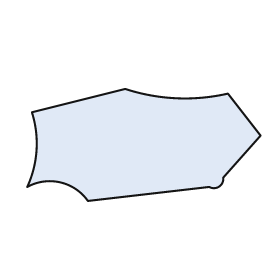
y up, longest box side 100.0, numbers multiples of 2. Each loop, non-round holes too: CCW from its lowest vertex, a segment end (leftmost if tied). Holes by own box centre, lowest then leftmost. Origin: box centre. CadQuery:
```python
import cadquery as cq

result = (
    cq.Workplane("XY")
    .moveTo(-24.0, -24.0)
    .lineTo(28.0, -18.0)
    .threePointArc((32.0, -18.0), (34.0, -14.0))
    .lineTo(50.0, 4.0)
    .lineTo(36.0, 22.0)
    .threePointArc((14.0, 20.0), (-8.0, 24.0))
    .lineTo(-48.0, 14.0)
    .threePointArc((-46.0, -2.0), (-50.0, -18.0))
    .threePointArc((-36.0, -16.0), (-24.0, -24.0))
    .close()
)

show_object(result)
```